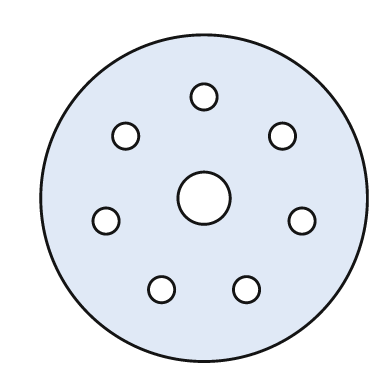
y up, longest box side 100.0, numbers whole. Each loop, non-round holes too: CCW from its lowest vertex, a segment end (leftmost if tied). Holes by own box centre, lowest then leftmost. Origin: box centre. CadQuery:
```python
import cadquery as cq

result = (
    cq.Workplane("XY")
    .moveTo(0.0, 0.0)
    .circle(50.0)
    .moveTo(-13.0, -28.0)
    .circle(4.0)
    .moveTo(13.0, -28.0)
    .circle(4.0)
    .moveTo(-30.0, -7.0)
    .circle(4.0)
    .moveTo(30.0, -7.0)
    .circle(4.0)
    .moveTo(0.0, 0.0)
    .circle(8.0)
    .moveTo(-24.0, 19.0)
    .circle(4.0)
    .moveTo(24.0, 19.0)
    .circle(4.0)
    .moveTo(0.0, 31.0)
    .circle(4.0)
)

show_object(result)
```